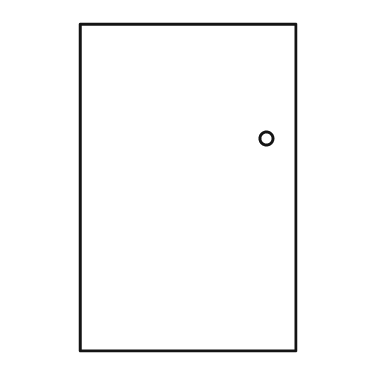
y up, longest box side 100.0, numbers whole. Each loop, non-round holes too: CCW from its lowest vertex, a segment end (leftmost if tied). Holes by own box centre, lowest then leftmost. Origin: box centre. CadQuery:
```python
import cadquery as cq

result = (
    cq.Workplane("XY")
    .moveTo(-33.0, -50.0)
    .lineTo(33.0, -50.0)
    .lineTo(33.0, 50.0)
    .lineTo(-33.0, 50.0)
    .close()
    .moveTo(24.0, 15.0)
    .circle(2.0)
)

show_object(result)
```